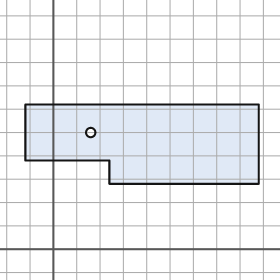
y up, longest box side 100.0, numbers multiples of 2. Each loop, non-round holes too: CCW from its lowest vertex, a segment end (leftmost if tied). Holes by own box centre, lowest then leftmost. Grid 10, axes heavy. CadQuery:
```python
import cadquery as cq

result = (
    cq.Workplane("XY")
    .moveTo(24.0, 28.0)
    .lineTo(88.0, 28.0)
    .lineTo(88.0, 62.0)
    .lineTo(-12.0, 62.0)
    .lineTo(-12.0, 38.0)
    .lineTo(24.0, 38.0)
    .close()
    .moveTo(16.0, 50.0)
    .circle(2.0)
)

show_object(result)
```